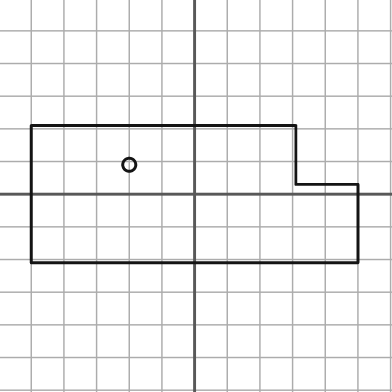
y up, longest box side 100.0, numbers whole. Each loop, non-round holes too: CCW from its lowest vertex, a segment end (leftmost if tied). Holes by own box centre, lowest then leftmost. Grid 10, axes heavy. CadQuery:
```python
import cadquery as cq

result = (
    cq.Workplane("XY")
    .moveTo(-50.0, -21.0)
    .lineTo(50.0, -21.0)
    .lineTo(50.0, 3.0)
    .lineTo(31.0, 3.0)
    .lineTo(31.0, 21.0)
    .lineTo(-50.0, 21.0)
    .close()
    .moveTo(-20.0, 9.0)
    .circle(2.0)
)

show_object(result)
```